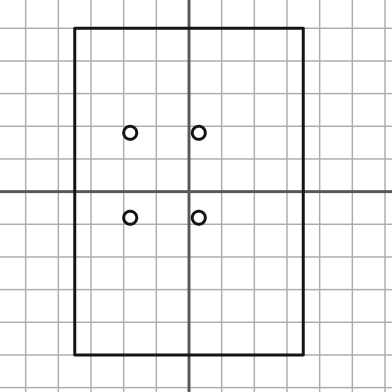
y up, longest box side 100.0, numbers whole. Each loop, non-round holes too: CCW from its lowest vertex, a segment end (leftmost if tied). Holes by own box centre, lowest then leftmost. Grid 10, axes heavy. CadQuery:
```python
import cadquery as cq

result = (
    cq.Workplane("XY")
    .moveTo(-35.0, -50.0)
    .lineTo(35.0, -50.0)
    .lineTo(35.0, 50.0)
    .lineTo(-35.0, 50.0)
    .close()
    .moveTo(-18.0, -8.0)
    .circle(2.0)
    .moveTo(3.0, -8.0)
    .circle(2.0)
    .moveTo(-18.0, 18.0)
    .circle(2.0)
    .moveTo(3.0, 18.0)
    .circle(2.0)
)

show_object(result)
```